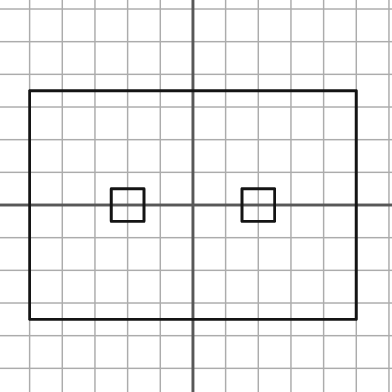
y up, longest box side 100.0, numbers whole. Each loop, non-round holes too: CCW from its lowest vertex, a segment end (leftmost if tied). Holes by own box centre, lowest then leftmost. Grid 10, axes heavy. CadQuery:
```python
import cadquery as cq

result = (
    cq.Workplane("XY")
    .moveTo(-50.0, -35.0)
    .lineTo(50.0, -35.0)
    .lineTo(50.0, 35.0)
    .lineTo(-50.0, 35.0)
    .close()
    .moveTo(-25.0, -5.0)
    .lineTo(-15.0, -5.0)
    .lineTo(-15.0, 5.0)
    .lineTo(-25.0, 5.0)
    .close()
    .moveTo(15.0, -5.0)
    .lineTo(25.0, -5.0)
    .lineTo(25.0, 5.0)
    .lineTo(15.0, 5.0)
    .close()
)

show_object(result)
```